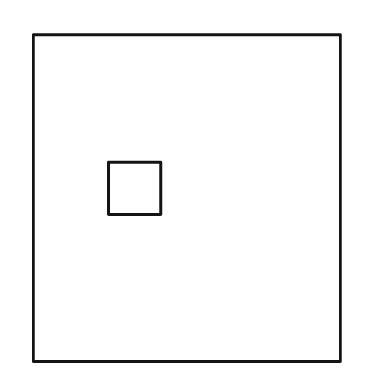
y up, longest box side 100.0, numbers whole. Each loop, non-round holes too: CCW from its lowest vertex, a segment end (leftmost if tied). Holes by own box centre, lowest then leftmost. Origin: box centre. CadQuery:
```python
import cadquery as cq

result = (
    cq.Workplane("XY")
    .moveTo(-47.0, -50.0)
    .lineTo(47.0, -50.0)
    .lineTo(47.0, 50.0)
    .lineTo(-47.0, 50.0)
    .close()
    .moveTo(-24.0, -5.0)
    .lineTo(-8.0, -5.0)
    .lineTo(-8.0, 11.0)
    .lineTo(-24.0, 11.0)
    .close()
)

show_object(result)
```